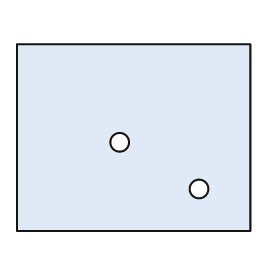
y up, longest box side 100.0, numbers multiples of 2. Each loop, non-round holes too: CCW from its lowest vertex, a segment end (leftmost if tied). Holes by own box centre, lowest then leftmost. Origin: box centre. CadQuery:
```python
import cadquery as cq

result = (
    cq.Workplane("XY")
    .moveTo(-50.0, -40.0)
    .lineTo(50.0, -40.0)
    .lineTo(50.0, 40.0)
    .lineTo(-50.0, 40.0)
    .close()
    .moveTo(28.0, -22.0)
    .circle(4.0)
    .moveTo(-6.0, -2.0)
    .circle(4.0)
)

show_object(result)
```